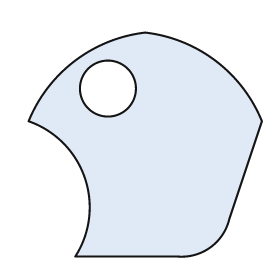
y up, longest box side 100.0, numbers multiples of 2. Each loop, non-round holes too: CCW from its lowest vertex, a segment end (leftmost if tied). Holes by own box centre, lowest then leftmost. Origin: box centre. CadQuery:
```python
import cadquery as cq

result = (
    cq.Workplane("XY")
    .moveTo(-30.0, -48.0)
    .lineTo(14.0, -48.0)
    .threePointArc((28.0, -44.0), (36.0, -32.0))
    .lineTo(50.0, 10.0)
    .threePointArc((30.0, 36.0), (0.0, 48.0))
    .threePointArc((-30.0, 36.0), (-50.0, 10.0))
    .threePointArc((-26.0, -14.0), (-30.0, -48.0))
    .close()
    .moveTo(-16.0, 24.0)
    .circle(12.0)
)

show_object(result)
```